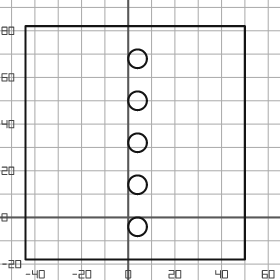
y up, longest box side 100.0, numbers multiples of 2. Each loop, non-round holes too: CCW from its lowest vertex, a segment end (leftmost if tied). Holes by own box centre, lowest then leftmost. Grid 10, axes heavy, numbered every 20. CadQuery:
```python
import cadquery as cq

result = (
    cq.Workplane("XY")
    .moveTo(-44.0, -18.0)
    .lineTo(50.0, -18.0)
    .lineTo(50.0, 82.0)
    .lineTo(-44.0, 82.0)
    .close()
    .moveTo(4.0, -4.0)
    .circle(4.0)
    .moveTo(4.0, 14.0)
    .circle(4.0)
    .moveTo(4.0, 32.0)
    .circle(4.0)
    .moveTo(4.0, 50.0)
    .circle(4.0)
    .moveTo(4.0, 68.0)
    .circle(4.0)
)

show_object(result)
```